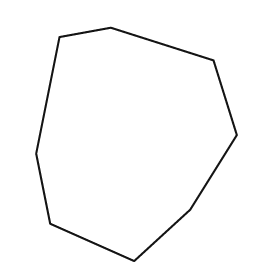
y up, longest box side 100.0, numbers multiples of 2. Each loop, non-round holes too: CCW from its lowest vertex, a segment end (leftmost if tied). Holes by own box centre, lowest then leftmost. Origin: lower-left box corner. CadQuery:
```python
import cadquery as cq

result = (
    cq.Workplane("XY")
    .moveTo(42.0, 0.0)
    .lineTo(66.0, 22.0)
    .lineTo(86.0, 54.0)
    .lineTo(76.0, 86.0)
    .lineTo(32.0, 100.0)
    .lineTo(10.0, 96.0)
    .lineTo(0.0, 46.0)
    .lineTo(6.0, 16.0)
    .close()
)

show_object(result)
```